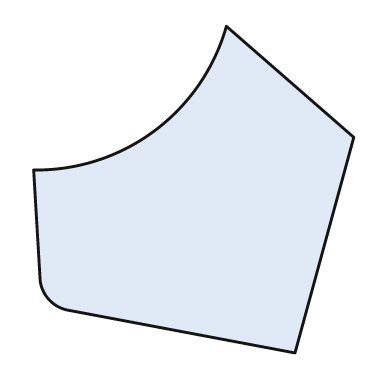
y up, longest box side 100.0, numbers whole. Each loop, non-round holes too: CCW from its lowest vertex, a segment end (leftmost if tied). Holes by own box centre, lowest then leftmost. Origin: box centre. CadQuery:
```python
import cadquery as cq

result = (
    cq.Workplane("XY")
    .moveTo(31.0, -50.0)
    .lineTo(49.0, 16.0)
    .lineTo(10.0, 50.0)
    .threePointArc((-12.0, 18.0), (-49.0, 6.0))
    .lineTo(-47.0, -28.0)
    .threePointArc((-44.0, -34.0), (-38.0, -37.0))
    .close()
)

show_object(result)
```